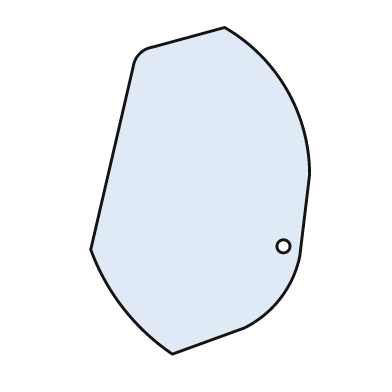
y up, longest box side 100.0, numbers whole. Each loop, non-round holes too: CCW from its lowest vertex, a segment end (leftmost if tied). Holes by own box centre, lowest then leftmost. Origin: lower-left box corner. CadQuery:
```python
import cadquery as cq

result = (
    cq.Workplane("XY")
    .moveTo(25.0, 0.0)
    .lineTo(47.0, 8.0)
    .threePointArc((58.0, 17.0), (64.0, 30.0))
    .lineTo(67.0, 55.0)
    .threePointArc((60.0, 81.0), (41.0, 100.0))
    .lineTo(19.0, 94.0)
    .threePointArc((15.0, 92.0), (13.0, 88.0))
    .lineTo(0.0, 32.0)
    .threePointArc((10.0, 14.0), (25.0, 0.0))
    .close()
    .moveTo(59.0, 33.0)
    .circle(2.0)
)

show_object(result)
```